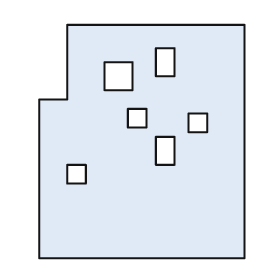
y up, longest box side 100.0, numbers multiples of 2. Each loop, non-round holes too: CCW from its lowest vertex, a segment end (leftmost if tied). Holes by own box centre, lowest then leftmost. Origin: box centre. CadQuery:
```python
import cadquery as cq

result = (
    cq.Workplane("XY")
    .moveTo(-44.0, -50.0)
    .lineTo(44.0, -50.0)
    .lineTo(44.0, 50.0)
    .lineTo(-32.0, 50.0)
    .lineTo(-32.0, 18.0)
    .lineTo(-44.0, 18.0)
    .close()
    .moveTo(-32.0, -18.0)
    .lineTo(-24.0, -18.0)
    .lineTo(-24.0, -10.0)
    .lineTo(-32.0, -10.0)
    .close()
    .moveTo(6.0, -10.0)
    .lineTo(14.0, -10.0)
    .lineTo(14.0, 2.0)
    .lineTo(6.0, 2.0)
    .close()
    .moveTo(20.0, 4.0)
    .lineTo(28.0, 4.0)
    .lineTo(28.0, 12.0)
    .lineTo(20.0, 12.0)
    .close()
    .moveTo(-6.0, 6.0)
    .lineTo(2.0, 6.0)
    .lineTo(2.0, 14.0)
    .lineTo(-6.0, 14.0)
    .close()
    .moveTo(-16.0, 22.0)
    .lineTo(-4.0, 22.0)
    .lineTo(-4.0, 34.0)
    .lineTo(-16.0, 34.0)
    .close()
    .moveTo(6.0, 28.0)
    .lineTo(14.0, 28.0)
    .lineTo(14.0, 40.0)
    .lineTo(6.0, 40.0)
    .close()
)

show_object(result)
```